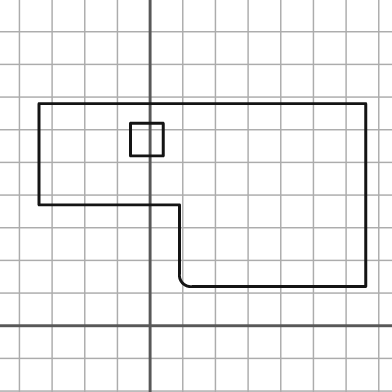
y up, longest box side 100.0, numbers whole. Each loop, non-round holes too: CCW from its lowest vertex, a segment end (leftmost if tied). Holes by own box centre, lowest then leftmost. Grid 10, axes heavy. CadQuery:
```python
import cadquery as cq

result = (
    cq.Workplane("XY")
    .moveTo(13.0, 12.0)
    .lineTo(66.0, 12.0)
    .lineTo(66.0, 68.0)
    .lineTo(-34.0, 68.0)
    .lineTo(-34.0, 37.0)
    .lineTo(9.0, 37.0)
    .lineTo(9.0, 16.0)
    .threePointArc((10.0, 13.0), (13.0, 12.0))
    .close()
    .moveTo(-6.0, 52.0)
    .lineTo(4.0, 52.0)
    .lineTo(4.0, 62.0)
    .lineTo(-6.0, 62.0)
    .close()
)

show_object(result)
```